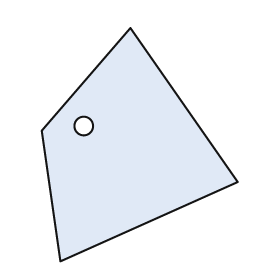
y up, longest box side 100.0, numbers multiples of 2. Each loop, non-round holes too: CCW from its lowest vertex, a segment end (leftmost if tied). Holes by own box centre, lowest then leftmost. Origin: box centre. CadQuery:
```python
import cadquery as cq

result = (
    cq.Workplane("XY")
    .moveTo(-34.0, -50.0)
    .lineTo(42.0, -16.0)
    .lineTo(-4.0, 50.0)
    .lineTo(-42.0, 6.0)
    .close()
    .moveTo(-24.0, 8.0)
    .circle(4.0)
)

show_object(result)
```